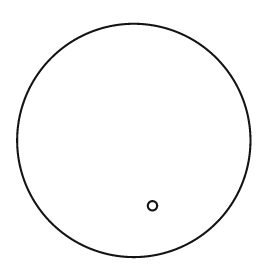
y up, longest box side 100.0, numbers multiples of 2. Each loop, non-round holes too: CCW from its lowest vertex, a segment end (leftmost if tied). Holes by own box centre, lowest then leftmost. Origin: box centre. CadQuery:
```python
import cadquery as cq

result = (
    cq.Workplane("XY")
    .moveTo(0.0, 0.0)
    .circle(50.0)
    .moveTo(8.0, -28.0)
    .circle(2.0)
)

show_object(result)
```